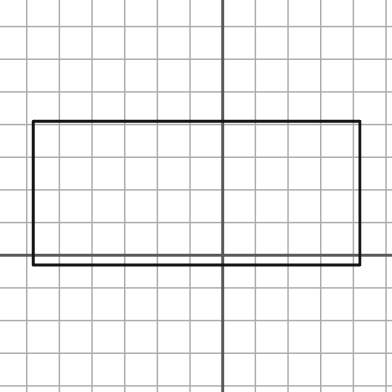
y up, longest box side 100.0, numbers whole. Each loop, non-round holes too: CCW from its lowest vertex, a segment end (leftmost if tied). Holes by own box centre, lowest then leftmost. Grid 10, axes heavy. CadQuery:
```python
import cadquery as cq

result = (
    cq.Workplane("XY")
    .moveTo(-58.0, -3.0)
    .lineTo(42.0, -3.0)
    .lineTo(42.0, 41.0)
    .lineTo(-58.0, 41.0)
    .close()
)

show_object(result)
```